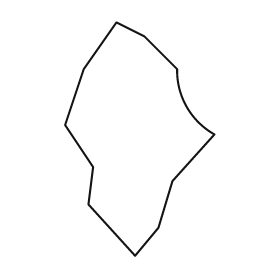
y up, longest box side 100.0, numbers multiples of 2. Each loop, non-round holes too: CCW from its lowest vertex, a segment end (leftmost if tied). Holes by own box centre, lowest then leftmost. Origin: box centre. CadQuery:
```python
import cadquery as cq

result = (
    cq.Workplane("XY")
    .moveTo(-2.0, -50.0)
    .lineTo(8.0, -38.0)
    .lineTo(14.0, -18.0)
    .lineTo(32.0, 2.0)
    .threePointArc((20.0, 14.0), (16.0, 30.0))
    .lineTo(2.0, 44.0)
    .lineTo(-10.0, 50.0)
    .lineTo(-24.0, 30.0)
    .lineTo(-32.0, 6.0)
    .lineTo(-20.0, -12.0)
    .lineTo(-22.0, -28.0)
    .close()
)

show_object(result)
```